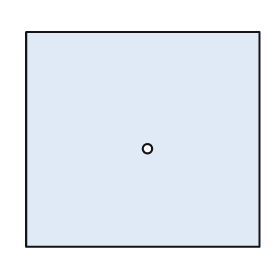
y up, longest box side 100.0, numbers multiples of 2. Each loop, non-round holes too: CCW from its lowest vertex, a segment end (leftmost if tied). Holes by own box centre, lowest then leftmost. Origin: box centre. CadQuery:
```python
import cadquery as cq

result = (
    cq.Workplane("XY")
    .moveTo(-50.0, -46.0)
    .lineTo(50.0, -46.0)
    .lineTo(50.0, 46.0)
    .lineTo(-50.0, 46.0)
    .close()
    .moveTo(2.0, -4.0)
    .circle(2.0)
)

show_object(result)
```